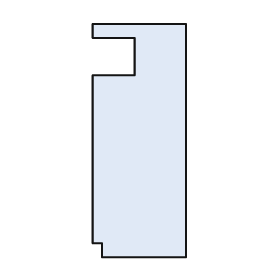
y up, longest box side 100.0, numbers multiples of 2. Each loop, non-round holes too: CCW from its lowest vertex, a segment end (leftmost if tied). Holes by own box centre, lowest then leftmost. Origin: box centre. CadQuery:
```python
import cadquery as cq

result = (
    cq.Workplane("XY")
    .moveTo(-16.0, -50.0)
    .lineTo(20.0, -50.0)
    .lineTo(20.0, 50.0)
    .lineTo(-20.0, 50.0)
    .lineTo(-20.0, 44.0)
    .lineTo(-2.0, 44.0)
    .lineTo(-2.0, 28.0)
    .lineTo(-20.0, 28.0)
    .lineTo(-20.0, -44.0)
    .lineTo(-16.0, -44.0)
    .close()
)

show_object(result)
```